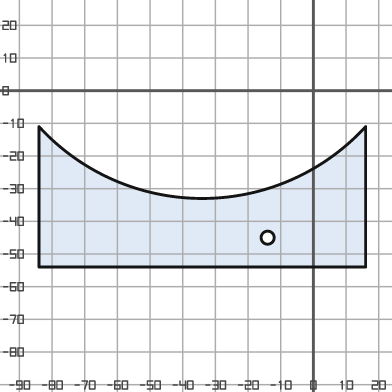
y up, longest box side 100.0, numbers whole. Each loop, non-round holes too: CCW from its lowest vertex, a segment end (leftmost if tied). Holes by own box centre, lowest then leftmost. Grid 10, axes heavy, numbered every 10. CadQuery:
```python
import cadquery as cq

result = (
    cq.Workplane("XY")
    .moveTo(-84.0, -54.0)
    .lineTo(16.0, -54.0)
    .lineTo(16.0, -11.0)
    .threePointArc((-34.0, -33.0), (-84.0, -11.0))
    .close()
    .moveTo(-14.0, -45.0)
    .circle(2.0)
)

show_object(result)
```